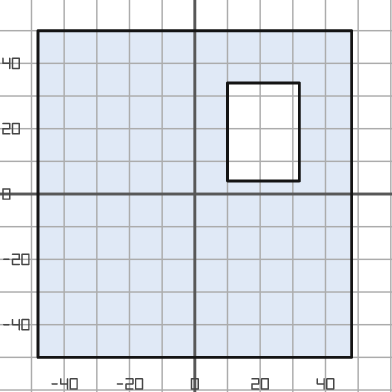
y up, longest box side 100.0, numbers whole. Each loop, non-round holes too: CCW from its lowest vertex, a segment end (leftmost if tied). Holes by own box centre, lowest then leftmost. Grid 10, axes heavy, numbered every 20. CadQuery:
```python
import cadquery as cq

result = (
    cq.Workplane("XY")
    .moveTo(-48.0, -50.0)
    .lineTo(48.0, -50.0)
    .lineTo(48.0, 50.0)
    .lineTo(-48.0, 50.0)
    .close()
    .moveTo(10.0, 4.0)
    .lineTo(32.0, 4.0)
    .lineTo(32.0, 34.0)
    .lineTo(10.0, 34.0)
    .close()
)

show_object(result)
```